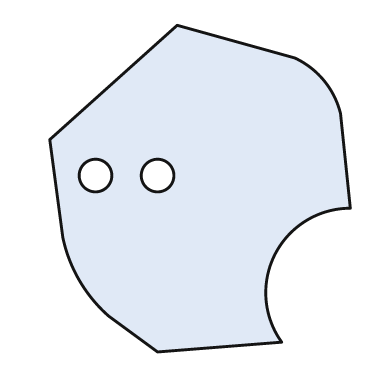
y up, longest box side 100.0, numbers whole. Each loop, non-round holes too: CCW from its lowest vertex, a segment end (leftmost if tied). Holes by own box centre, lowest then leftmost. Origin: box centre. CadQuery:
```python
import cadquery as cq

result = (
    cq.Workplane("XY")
    .moveTo(-13.0, -50.0)
    .lineTo(25.0, -47.0)
    .threePointArc((23.0, -20.0), (46.0, -6.0))
    .lineTo(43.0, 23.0)
    .threePointArc((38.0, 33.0), (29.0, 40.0))
    .lineTo(-7.0, 50.0)
    .lineTo(-46.0, 15.0)
    .lineTo(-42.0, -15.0)
    .threePointArc((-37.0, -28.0), (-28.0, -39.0))
    .close()
    .moveTo(-32.0, 4.0)
    .circle(5.0)
    .moveTo(-13.0, 4.0)
    .circle(5.0)
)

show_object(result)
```